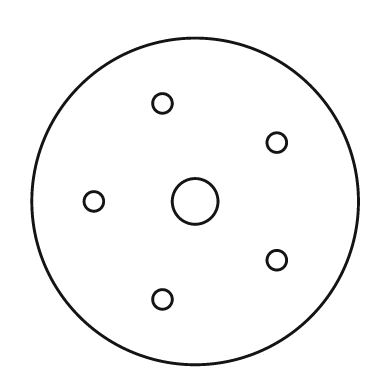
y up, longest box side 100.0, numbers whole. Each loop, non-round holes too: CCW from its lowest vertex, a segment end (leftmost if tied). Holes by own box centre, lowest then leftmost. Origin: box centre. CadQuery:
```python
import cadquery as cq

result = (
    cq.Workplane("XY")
    .moveTo(0.0, 0.0)
    .circle(50.0)
    .moveTo(-10.0, -30.0)
    .circle(3.0)
    .moveTo(25.0, -18.0)
    .circle(3.0)
    .moveTo(-31.0, 0.0)
    .circle(3.0)
    .moveTo(0.0, 0.0)
    .circle(7.0)
    .moveTo(25.0, 18.0)
    .circle(3.0)
    .moveTo(-10.0, 30.0)
    .circle(3.0)
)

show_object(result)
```